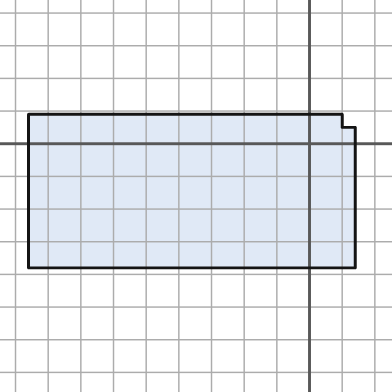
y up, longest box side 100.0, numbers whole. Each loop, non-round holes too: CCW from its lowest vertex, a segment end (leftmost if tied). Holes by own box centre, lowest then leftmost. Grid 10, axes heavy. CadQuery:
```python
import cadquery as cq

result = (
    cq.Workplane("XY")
    .moveTo(-86.0, -38.0)
    .lineTo(14.0, -38.0)
    .lineTo(14.0, 5.0)
    .lineTo(10.0, 5.0)
    .lineTo(10.0, 9.0)
    .lineTo(-86.0, 9.0)
    .close()
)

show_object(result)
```